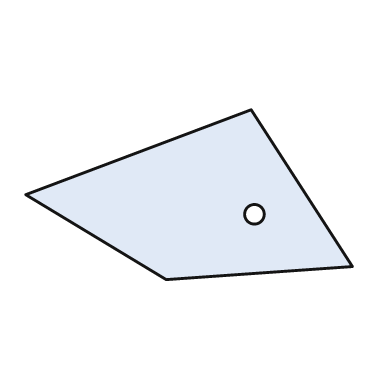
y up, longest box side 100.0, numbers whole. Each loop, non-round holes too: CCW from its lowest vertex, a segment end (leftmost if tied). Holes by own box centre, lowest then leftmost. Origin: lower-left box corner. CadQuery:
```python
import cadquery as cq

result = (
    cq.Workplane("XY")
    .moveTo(43.0, 0.0)
    .lineTo(100.0, 4.0)
    .lineTo(69.0, 52.0)
    .lineTo(0.0, 26.0)
    .close()
    .moveTo(70.0, 20.0)
    .circle(3.0)
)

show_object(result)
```